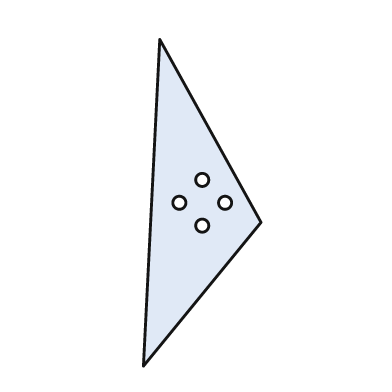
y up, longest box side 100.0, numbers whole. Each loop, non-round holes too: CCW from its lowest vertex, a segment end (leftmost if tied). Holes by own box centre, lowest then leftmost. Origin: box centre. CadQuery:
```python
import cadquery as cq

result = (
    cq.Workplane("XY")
    .moveTo(-18.0, -50.0)
    .lineTo(18.0, -6.0)
    .lineTo(-13.0, 50.0)
    .close()
    .moveTo(0.0, -7.0)
    .circle(2.0)
    .moveTo(-7.0, 0.0)
    .circle(2.0)
    .moveTo(7.0, 0.0)
    .circle(2.0)
    .moveTo(0.0, 7.0)
    .circle(2.0)
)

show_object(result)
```